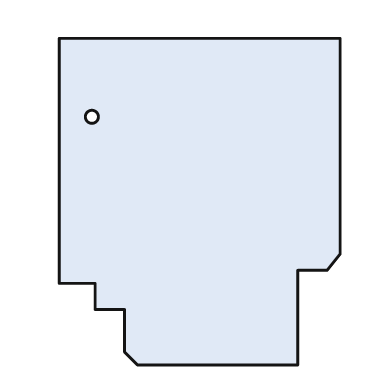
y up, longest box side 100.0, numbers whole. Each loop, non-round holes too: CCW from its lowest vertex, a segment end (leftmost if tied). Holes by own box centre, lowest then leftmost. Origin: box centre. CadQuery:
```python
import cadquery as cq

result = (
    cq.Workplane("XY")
    .moveTo(-19.0, -50.0)
    .lineTo(30.0, -50.0)
    .lineTo(30.0, -21.0)
    .lineTo(39.0, -21.0)
    .lineTo(43.0, -16.0)
    .lineTo(43.0, 50.0)
    .lineTo(-43.0, 50.0)
    .lineTo(-43.0, -25.0)
    .lineTo(-32.0, -25.0)
    .lineTo(-32.0, -33.0)
    .lineTo(-23.0, -33.0)
    .lineTo(-23.0, -46.0)
    .close()
    .moveTo(-33.0, 26.0)
    .circle(2.0)
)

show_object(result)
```